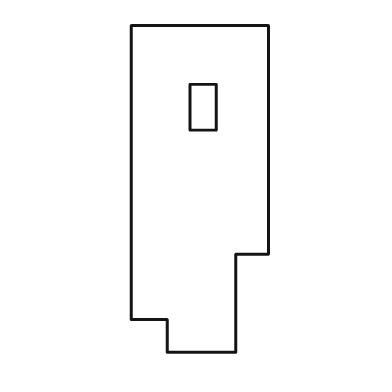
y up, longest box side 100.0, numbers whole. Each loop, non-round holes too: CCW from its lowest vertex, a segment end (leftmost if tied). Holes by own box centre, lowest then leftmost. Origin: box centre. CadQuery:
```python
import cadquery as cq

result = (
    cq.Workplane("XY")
    .moveTo(-10.0, -50.0)
    .lineTo(11.0, -50.0)
    .lineTo(11.0, -20.0)
    .lineTo(21.0, -20.0)
    .lineTo(21.0, 50.0)
    .lineTo(-21.0, 50.0)
    .lineTo(-21.0, -40.0)
    .lineTo(-10.0, -40.0)
    .close()
    .moveTo(-3.0, 18.0)
    .lineTo(5.0, 18.0)
    .lineTo(5.0, 32.0)
    .lineTo(-3.0, 32.0)
    .close()
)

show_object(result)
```